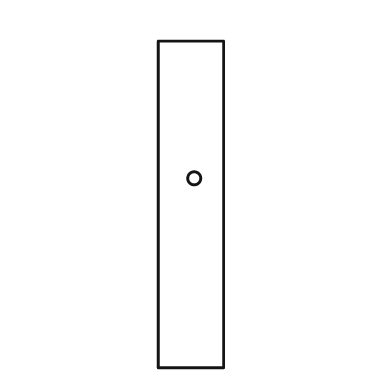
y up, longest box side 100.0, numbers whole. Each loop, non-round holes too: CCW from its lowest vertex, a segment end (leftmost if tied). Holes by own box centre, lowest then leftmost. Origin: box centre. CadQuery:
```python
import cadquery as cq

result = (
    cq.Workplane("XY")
    .moveTo(-10.0, -50.0)
    .lineTo(10.0, -50.0)
    .lineTo(10.0, 50.0)
    .lineTo(-10.0, 50.0)
    .close()
    .moveTo(1.0, 8.0)
    .circle(2.0)
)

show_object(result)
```